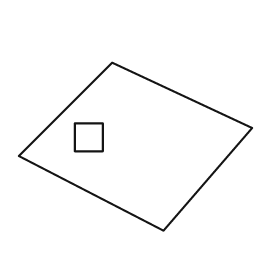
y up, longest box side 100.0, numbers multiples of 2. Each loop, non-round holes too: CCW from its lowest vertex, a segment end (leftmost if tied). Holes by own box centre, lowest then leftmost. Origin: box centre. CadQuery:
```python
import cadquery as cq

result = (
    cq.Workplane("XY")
    .moveTo(12.0, -36.0)
    .lineTo(50.0, 8.0)
    .lineTo(-10.0, 36.0)
    .lineTo(-50.0, -4.0)
    .close()
    .moveTo(-26.0, -2.0)
    .lineTo(-14.0, -2.0)
    .lineTo(-14.0, 10.0)
    .lineTo(-26.0, 10.0)
    .close()
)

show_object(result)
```